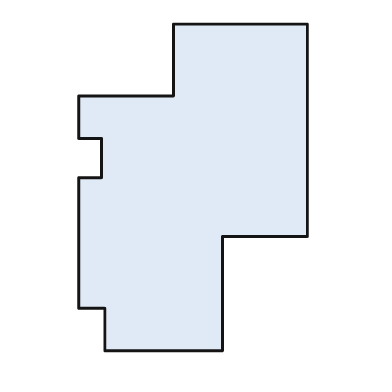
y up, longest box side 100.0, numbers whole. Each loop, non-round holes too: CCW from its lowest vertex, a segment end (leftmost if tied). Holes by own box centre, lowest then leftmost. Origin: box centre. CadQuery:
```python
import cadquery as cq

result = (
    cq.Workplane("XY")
    .moveTo(-27.0, -50.0)
    .lineTo(9.0, -50.0)
    .lineTo(9.0, -15.0)
    .lineTo(35.0, -15.0)
    .lineTo(35.0, 50.0)
    .lineTo(-6.0, 50.0)
    .lineTo(-6.0, 28.0)
    .lineTo(-35.0, 28.0)
    .lineTo(-35.0, 15.0)
    .lineTo(-28.0, 15.0)
    .lineTo(-28.0, 3.0)
    .lineTo(-35.0, 3.0)
    .lineTo(-35.0, -37.0)
    .lineTo(-27.0, -37.0)
    .close()
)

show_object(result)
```